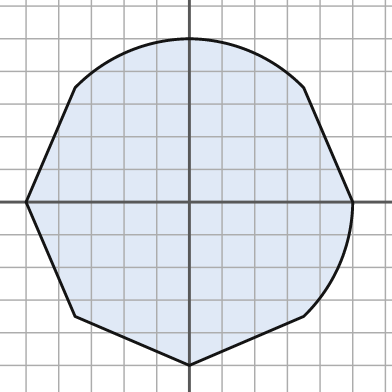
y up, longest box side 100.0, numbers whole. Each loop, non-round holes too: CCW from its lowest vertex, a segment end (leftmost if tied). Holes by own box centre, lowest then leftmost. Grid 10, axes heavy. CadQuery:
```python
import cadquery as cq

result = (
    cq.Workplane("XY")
    .moveTo(0.0, -50.0)
    .lineTo(35.0, -35.0)
    .threePointArc((46.0, -19.0), (50.0, 0.0))
    .lineTo(35.0, 35.0)
    .threePointArc((19.0, 46.0), (0.0, 50.0))
    .threePointArc((-19.0, 46.0), (-35.0, 35.0))
    .lineTo(-50.0, 0.0)
    .lineTo(-35.0, -35.0)
    .close()
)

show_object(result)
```